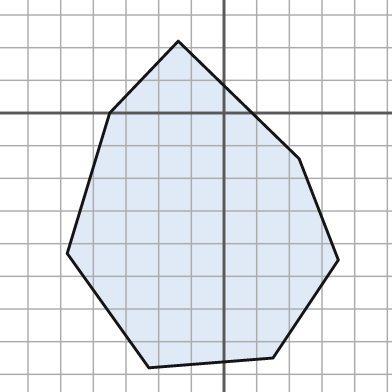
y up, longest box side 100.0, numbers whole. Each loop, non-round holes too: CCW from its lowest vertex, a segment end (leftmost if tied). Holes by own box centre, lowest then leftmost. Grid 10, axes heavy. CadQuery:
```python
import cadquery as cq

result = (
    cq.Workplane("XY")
    .moveTo(-23.0, -78.0)
    .lineTo(15.0, -75.0)
    .lineTo(35.0, -45.0)
    .lineTo(23.0, -14.0)
    .lineTo(-14.0, 22.0)
    .lineTo(-35.0, 0.0)
    .lineTo(-48.0, -43.0)
    .close()
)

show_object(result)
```